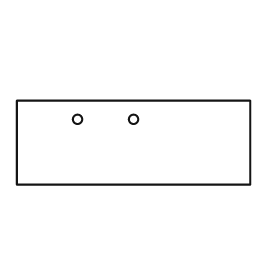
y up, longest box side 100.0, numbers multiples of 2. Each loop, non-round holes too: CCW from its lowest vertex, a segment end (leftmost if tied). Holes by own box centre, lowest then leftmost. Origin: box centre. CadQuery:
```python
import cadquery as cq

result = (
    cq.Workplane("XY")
    .moveTo(-50.0, -18.0)
    .lineTo(50.0, -18.0)
    .lineTo(50.0, 18.0)
    .lineTo(-50.0, 18.0)
    .close()
    .moveTo(-24.0, 10.0)
    .circle(2.0)
    .moveTo(0.0, 10.0)
    .circle(2.0)
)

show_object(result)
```